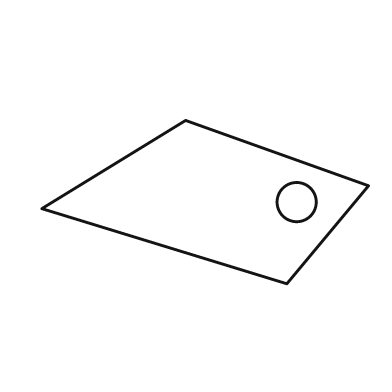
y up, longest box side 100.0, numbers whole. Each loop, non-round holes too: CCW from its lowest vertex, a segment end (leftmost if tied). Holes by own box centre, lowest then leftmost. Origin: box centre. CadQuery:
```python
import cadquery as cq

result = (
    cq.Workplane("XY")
    .moveTo(25.0, -25.0)
    .lineTo(50.0, 5.0)
    .lineTo(-6.0, 25.0)
    .lineTo(-50.0, -2.0)
    .close()
    .moveTo(28.0, 0.0)
    .circle(6.0)
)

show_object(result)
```